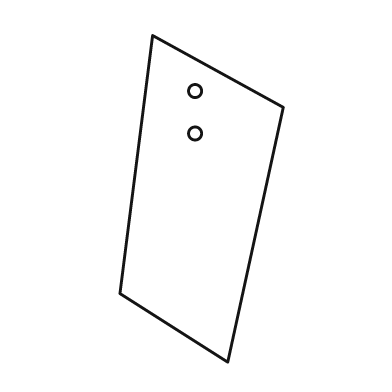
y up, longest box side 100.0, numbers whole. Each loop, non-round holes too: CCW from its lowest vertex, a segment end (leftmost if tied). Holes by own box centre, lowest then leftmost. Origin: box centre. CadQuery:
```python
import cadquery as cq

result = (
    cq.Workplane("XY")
    .moveTo(8.0, -50.0)
    .lineTo(25.0, 28.0)
    .lineTo(-15.0, 50.0)
    .lineTo(-25.0, -29.0)
    .close()
    .moveTo(-2.0, 20.0)
    .circle(2.0)
    .moveTo(-2.0, 33.0)
    .circle(2.0)
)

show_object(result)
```